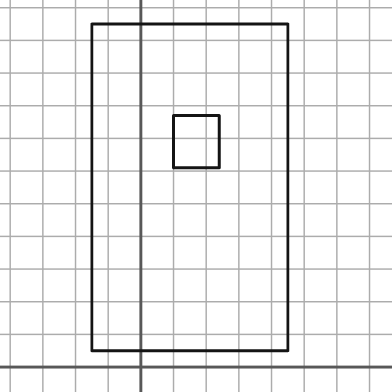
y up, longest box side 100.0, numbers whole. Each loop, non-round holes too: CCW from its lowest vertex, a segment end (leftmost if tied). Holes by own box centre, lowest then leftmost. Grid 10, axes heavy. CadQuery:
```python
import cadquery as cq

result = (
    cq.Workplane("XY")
    .moveTo(-15.0, 5.0)
    .lineTo(45.0, 5.0)
    .lineTo(45.0, 105.0)
    .lineTo(-15.0, 105.0)
    .close()
    .moveTo(10.0, 61.0)
    .lineTo(24.0, 61.0)
    .lineTo(24.0, 77.0)
    .lineTo(10.0, 77.0)
    .close()
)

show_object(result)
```